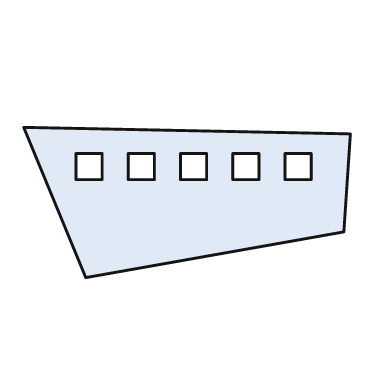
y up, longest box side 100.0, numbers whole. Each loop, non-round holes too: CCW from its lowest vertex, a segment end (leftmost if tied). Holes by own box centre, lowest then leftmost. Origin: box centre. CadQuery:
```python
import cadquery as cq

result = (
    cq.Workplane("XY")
    .moveTo(-31.0, -23.0)
    .lineTo(48.0, -9.0)
    .lineTo(50.0, 21.0)
    .lineTo(-50.0, 23.0)
    .close()
    .moveTo(-34.0, 7.0)
    .lineTo(-26.0, 7.0)
    .lineTo(-26.0, 15.0)
    .lineTo(-34.0, 15.0)
    .close()
    .moveTo(-18.0, 7.0)
    .lineTo(-10.0, 7.0)
    .lineTo(-10.0, 15.0)
    .lineTo(-18.0, 15.0)
    .close()
    .moveTo(-2.0, 7.0)
    .lineTo(6.0, 7.0)
    .lineTo(6.0, 15.0)
    .lineTo(-2.0, 15.0)
    .close()
    .moveTo(14.0, 7.0)
    .lineTo(22.0, 7.0)
    .lineTo(22.0, 15.0)
    .lineTo(14.0, 15.0)
    .close()
    .moveTo(30.0, 7.0)
    .lineTo(38.0, 7.0)
    .lineTo(38.0, 15.0)
    .lineTo(30.0, 15.0)
    .close()
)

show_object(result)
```